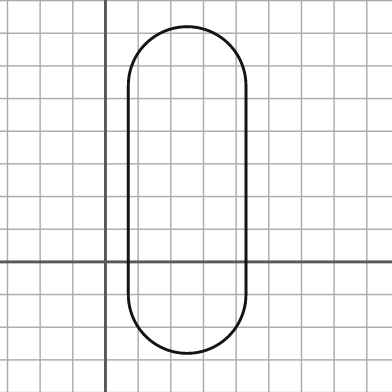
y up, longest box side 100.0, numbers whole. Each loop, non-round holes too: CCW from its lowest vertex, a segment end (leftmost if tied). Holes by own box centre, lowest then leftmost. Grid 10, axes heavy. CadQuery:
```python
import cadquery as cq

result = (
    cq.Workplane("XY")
    .moveTo(7.0, -10.0)
    .threePointArc((25.0, -28.0), (43.0, -10.0))
    .lineTo(43.0, 54.0)
    .threePointArc((25.0, 72.0), (7.0, 54.0))
    .close()
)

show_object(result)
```